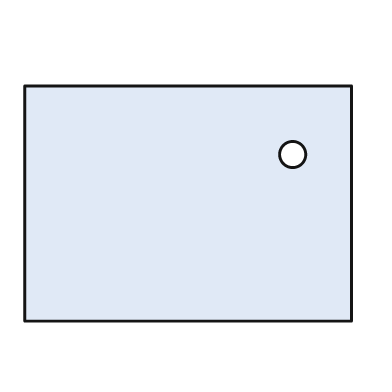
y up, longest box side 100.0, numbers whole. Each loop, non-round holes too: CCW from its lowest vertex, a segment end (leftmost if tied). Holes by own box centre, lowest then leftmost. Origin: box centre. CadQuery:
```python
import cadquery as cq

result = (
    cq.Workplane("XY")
    .moveTo(-50.0, -36.0)
    .lineTo(50.0, -36.0)
    .lineTo(50.0, 36.0)
    .lineTo(-50.0, 36.0)
    .close()
    .moveTo(32.0, 15.0)
    .circle(4.0)
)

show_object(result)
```